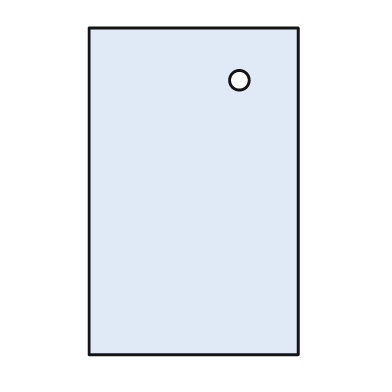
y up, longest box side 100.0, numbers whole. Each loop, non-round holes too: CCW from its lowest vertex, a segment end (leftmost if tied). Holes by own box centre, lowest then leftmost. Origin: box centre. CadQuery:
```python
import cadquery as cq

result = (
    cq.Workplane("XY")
    .moveTo(-32.0, -50.0)
    .lineTo(32.0, -50.0)
    .lineTo(32.0, 50.0)
    .lineTo(-32.0, 50.0)
    .close()
    .moveTo(14.0, 34.0)
    .circle(3.0)
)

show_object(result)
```